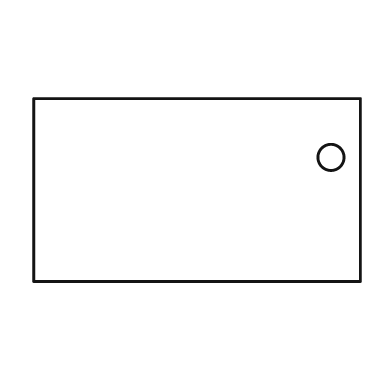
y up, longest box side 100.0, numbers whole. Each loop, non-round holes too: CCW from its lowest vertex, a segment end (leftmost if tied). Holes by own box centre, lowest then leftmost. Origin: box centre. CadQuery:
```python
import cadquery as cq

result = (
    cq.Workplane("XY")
    .moveTo(-50.0, -28.0)
    .lineTo(50.0, -28.0)
    .lineTo(50.0, 28.0)
    .lineTo(-50.0, 28.0)
    .close()
    .moveTo(41.0, 10.0)
    .circle(4.0)
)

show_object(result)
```